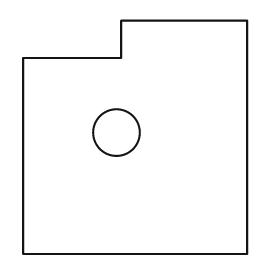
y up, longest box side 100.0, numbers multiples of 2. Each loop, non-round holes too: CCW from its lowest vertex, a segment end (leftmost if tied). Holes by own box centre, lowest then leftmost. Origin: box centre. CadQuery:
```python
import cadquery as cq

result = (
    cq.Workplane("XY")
    .moveTo(-48.0, -50.0)
    .lineTo(48.0, -50.0)
    .lineTo(48.0, 50.0)
    .lineTo(-6.0, 50.0)
    .lineTo(-6.0, 34.0)
    .lineTo(-48.0, 34.0)
    .close()
    .moveTo(-8.0, 2.0)
    .circle(10.0)
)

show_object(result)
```